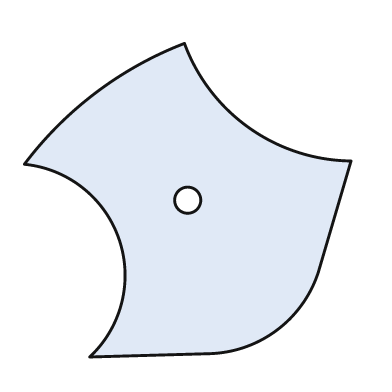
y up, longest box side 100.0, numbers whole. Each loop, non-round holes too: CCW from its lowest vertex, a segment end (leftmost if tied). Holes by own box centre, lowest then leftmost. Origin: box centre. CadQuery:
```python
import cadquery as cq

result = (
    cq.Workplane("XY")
    .moveTo(-30.0, -48.0)
    .lineTo(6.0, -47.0)
    .threePointArc((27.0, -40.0), (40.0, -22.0))
    .lineTo(50.0, 12.0)
    .threePointArc((19.0, 22.0), (-1.0, 48.0))
    .threePointArc((-28.0, 33.0), (-50.0, 11.0))
    .threePointArc((-21.0, -12.0), (-30.0, -48.0))
    .close()
    .moveTo(0.0, 0.0)
    .circle(4.0)
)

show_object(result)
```